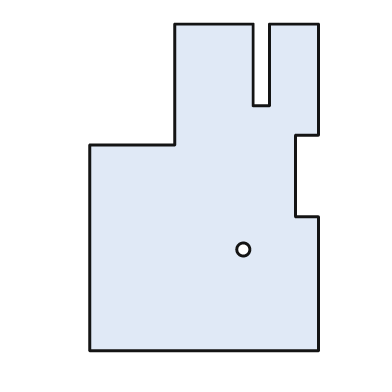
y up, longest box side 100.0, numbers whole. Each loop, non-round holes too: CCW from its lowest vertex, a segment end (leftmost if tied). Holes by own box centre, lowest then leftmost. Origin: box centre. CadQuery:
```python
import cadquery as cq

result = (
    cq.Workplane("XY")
    .moveTo(-35.0, -50.0)
    .lineTo(35.0, -50.0)
    .lineTo(35.0, -9.0)
    .lineTo(28.0, -9.0)
    .lineTo(28.0, 16.0)
    .lineTo(35.0, 16.0)
    .lineTo(35.0, 50.0)
    .lineTo(20.0, 50.0)
    .lineTo(20.0, 25.0)
    .lineTo(15.0, 25.0)
    .lineTo(15.0, 50.0)
    .lineTo(-9.0, 50.0)
    .lineTo(-9.0, 13.0)
    .lineTo(-35.0, 13.0)
    .close()
    .moveTo(12.0, -19.0)
    .circle(2.0)
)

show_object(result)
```